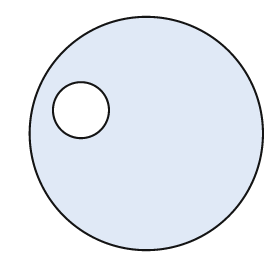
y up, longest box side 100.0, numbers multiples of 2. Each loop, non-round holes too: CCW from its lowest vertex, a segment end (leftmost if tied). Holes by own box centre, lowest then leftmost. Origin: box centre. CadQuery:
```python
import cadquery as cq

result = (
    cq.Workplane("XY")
    .moveTo(0.0, 0.0)
    .circle(50.0)
    .moveTo(-28.0, 10.0)
    .circle(12.0)
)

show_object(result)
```